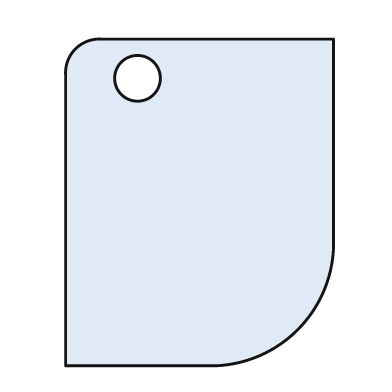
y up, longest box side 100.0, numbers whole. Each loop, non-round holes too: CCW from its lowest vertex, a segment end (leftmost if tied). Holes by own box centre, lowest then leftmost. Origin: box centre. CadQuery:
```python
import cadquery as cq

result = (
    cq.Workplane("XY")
    .moveTo(-41.0, -50.0)
    .lineTo(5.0, -50.0)
    .threePointArc((30.0, -39.0), (41.0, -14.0))
    .lineTo(41.0, 50.0)
    .lineTo(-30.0, 50.0)
    .threePointArc((-38.0, 47.0), (-41.0, 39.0))
    .close()
    .moveTo(-19.0, 38.0)
    .circle(7.0)
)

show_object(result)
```